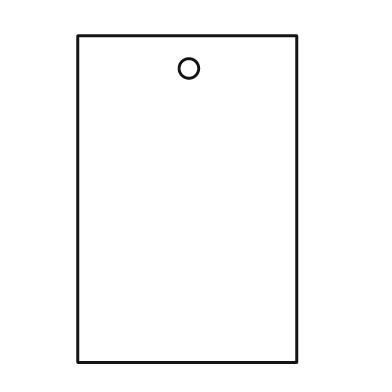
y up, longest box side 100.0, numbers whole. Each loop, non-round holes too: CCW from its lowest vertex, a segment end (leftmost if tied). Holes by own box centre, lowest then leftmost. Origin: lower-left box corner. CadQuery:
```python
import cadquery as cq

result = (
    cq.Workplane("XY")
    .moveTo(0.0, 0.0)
    .lineTo(67.0, 0.0)
    .lineTo(67.0, 100.0)
    .lineTo(0.0, 100.0)
    .close()
    .moveTo(34.0, 90.0)
    .circle(3.0)
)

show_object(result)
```